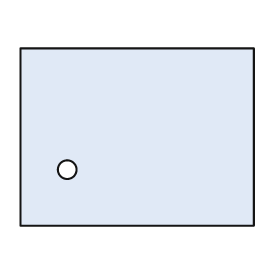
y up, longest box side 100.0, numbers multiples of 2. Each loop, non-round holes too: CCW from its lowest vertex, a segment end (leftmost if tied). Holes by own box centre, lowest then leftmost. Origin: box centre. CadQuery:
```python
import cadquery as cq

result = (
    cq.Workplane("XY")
    .moveTo(-50.0, -38.0)
    .lineTo(50.0, -38.0)
    .lineTo(50.0, 38.0)
    .lineTo(-50.0, 38.0)
    .close()
    .moveTo(-30.0, -14.0)
    .circle(4.0)
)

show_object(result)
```